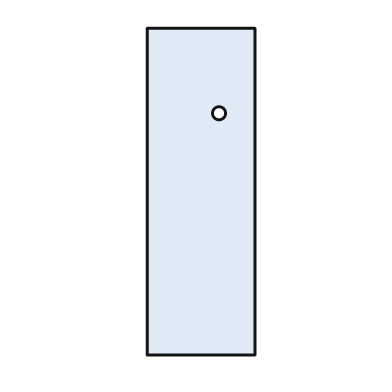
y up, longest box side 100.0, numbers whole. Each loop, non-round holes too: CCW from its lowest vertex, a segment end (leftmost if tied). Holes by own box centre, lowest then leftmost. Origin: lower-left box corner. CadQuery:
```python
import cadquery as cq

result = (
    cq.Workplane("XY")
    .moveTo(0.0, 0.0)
    .lineTo(33.0, 0.0)
    .lineTo(33.0, 100.0)
    .lineTo(0.0, 100.0)
    .close()
    .moveTo(22.0, 74.0)
    .circle(2.0)
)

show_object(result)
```